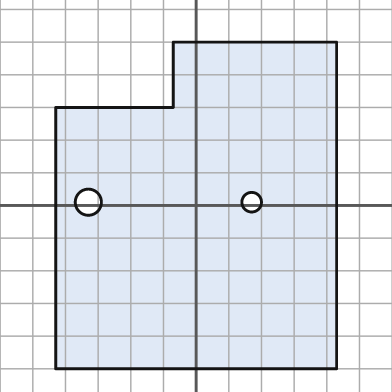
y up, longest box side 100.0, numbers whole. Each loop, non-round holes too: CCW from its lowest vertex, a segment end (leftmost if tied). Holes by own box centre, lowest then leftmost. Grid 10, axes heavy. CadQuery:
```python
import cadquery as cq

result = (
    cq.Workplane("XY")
    .moveTo(-43.0, -50.0)
    .lineTo(43.0, -50.0)
    .lineTo(43.0, 50.0)
    .lineTo(-7.0, 50.0)
    .lineTo(-7.0, 30.0)
    .lineTo(-43.0, 30.0)
    .close()
    .moveTo(-33.0, 1.0)
    .circle(4.0)
    .moveTo(17.0, 1.0)
    .circle(3.0)
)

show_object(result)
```